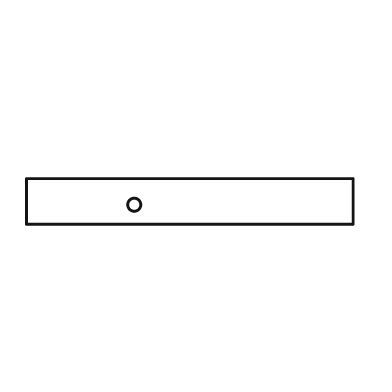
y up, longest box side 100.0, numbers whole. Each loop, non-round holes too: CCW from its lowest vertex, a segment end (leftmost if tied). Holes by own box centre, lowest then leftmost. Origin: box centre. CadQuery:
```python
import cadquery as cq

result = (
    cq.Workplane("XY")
    .moveTo(-50.0, -7.0)
    .lineTo(50.0, -7.0)
    .lineTo(50.0, 7.0)
    .lineTo(-50.0, 7.0)
    .close()
    .moveTo(-17.0, -1.0)
    .circle(2.0)
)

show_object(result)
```